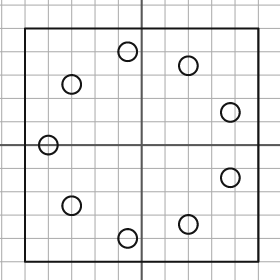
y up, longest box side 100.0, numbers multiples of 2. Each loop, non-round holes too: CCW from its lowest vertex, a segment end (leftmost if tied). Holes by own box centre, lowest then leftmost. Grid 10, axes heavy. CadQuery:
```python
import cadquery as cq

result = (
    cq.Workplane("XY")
    .moveTo(-50.0, -50.0)
    .lineTo(50.0, -50.0)
    .lineTo(50.0, 50.0)
    .lineTo(-50.0, 50.0)
    .close()
    .moveTo(-6.0, -40.0)
    .circle(4.0)
    .moveTo(20.0, -34.0)
    .circle(4.0)
    .moveTo(-30.0, -26.0)
    .circle(4.0)
    .moveTo(38.0, -14.0)
    .circle(4.0)
    .moveTo(-40.0, 0.0)
    .circle(4.0)
    .moveTo(38.0, 14.0)
    .circle(4.0)
    .moveTo(-30.0, 26.0)
    .circle(4.0)
    .moveTo(20.0, 34.0)
    .circle(4.0)
    .moveTo(-6.0, 40.0)
    .circle(4.0)
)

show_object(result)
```